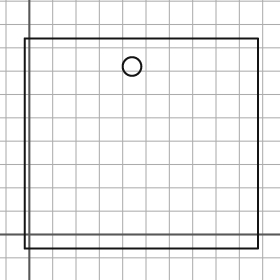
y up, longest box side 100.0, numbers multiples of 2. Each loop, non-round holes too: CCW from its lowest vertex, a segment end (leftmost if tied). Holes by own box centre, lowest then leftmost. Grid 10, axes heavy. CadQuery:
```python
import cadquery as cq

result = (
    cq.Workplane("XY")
    .moveTo(-2.0, -6.0)
    .lineTo(98.0, -6.0)
    .lineTo(98.0, 84.0)
    .lineTo(-2.0, 84.0)
    .close()
    .moveTo(44.0, 72.0)
    .circle(4.0)
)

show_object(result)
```